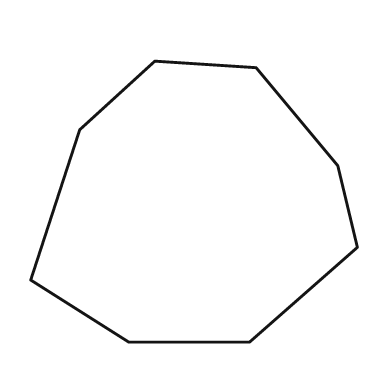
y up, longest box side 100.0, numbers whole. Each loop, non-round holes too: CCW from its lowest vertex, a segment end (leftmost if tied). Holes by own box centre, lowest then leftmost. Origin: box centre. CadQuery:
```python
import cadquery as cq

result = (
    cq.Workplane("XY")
    .moveTo(-20.0, -43.0)
    .lineTo(17.0, -43.0)
    .lineTo(50.0, -14.0)
    .lineTo(44.0, 11.0)
    .lineTo(19.0, 41.0)
    .lineTo(-12.0, 43.0)
    .lineTo(-35.0, 22.0)
    .lineTo(-50.0, -24.0)
    .close()
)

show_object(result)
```